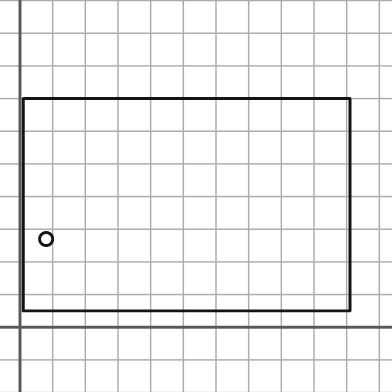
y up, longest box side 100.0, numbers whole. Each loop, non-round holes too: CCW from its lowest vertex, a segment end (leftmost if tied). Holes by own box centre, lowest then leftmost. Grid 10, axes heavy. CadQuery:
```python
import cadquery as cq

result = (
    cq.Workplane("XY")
    .moveTo(1.0, 5.0)
    .lineTo(101.0, 5.0)
    .lineTo(101.0, 70.0)
    .lineTo(1.0, 70.0)
    .close()
    .moveTo(8.0, 27.0)
    .circle(2.0)
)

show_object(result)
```